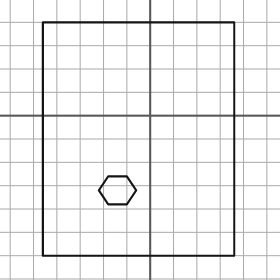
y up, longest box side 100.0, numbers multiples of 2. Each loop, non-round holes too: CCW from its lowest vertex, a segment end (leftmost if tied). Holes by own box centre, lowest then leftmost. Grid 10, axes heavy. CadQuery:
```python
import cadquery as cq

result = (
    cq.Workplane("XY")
    .moveTo(-46.0, -60.0)
    .lineTo(36.0, -60.0)
    .lineTo(36.0, 40.0)
    .lineTo(-46.0, 40.0)
    .close()
    .moveTo(-18.0, -38.0)
    .lineTo(-10.0, -38.0)
    .lineTo(-6.0, -32.0)
    .lineTo(-10.0, -26.0)
    .lineTo(-18.0, -26.0)
    .lineTo(-22.0, -32.0)
    .close()
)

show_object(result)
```